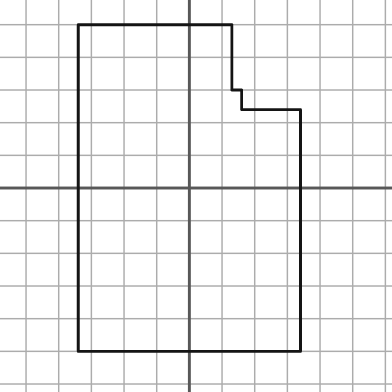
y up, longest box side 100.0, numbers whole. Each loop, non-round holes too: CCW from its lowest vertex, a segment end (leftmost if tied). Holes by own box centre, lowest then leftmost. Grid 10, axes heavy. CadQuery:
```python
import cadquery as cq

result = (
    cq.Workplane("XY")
    .moveTo(-34.0, -50.0)
    .lineTo(34.0, -50.0)
    .lineTo(34.0, 24.0)
    .lineTo(16.0, 24.0)
    .lineTo(16.0, 30.0)
    .lineTo(13.0, 30.0)
    .lineTo(13.0, 50.0)
    .lineTo(-34.0, 50.0)
    .close()
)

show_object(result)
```